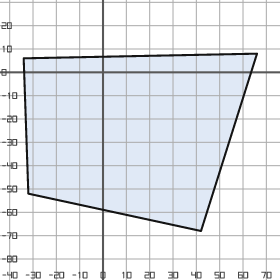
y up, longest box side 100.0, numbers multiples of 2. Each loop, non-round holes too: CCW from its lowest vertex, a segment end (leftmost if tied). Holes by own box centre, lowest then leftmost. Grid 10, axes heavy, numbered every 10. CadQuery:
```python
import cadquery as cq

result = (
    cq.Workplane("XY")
    .moveTo(42.0, -68.0)
    .lineTo(66.0, 8.0)
    .lineTo(-34.0, 6.0)
    .lineTo(-32.0, -52.0)
    .close()
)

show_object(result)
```